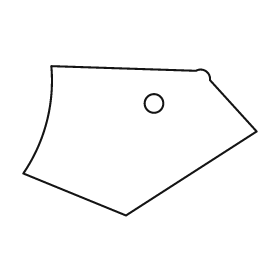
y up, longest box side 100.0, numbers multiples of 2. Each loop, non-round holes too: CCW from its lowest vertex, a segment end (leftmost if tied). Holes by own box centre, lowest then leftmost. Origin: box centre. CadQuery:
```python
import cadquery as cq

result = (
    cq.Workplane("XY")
    .moveTo(-6.0, -32.0)
    .lineTo(50.0, 4.0)
    .lineTo(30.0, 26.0)
    .threePointArc((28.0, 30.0), (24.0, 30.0))
    .lineTo(-38.0, 32.0)
    .threePointArc((-40.0, 8.0), (-50.0, -14.0))
    .close()
    .moveTo(6.0, 16.0)
    .circle(4.0)
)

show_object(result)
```